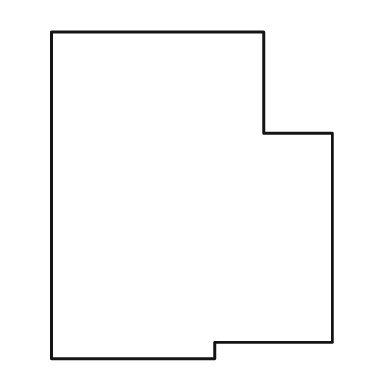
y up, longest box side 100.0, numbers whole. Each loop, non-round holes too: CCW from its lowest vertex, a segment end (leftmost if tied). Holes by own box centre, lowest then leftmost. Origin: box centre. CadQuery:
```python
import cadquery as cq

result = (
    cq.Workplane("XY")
    .moveTo(-43.0, -50.0)
    .lineTo(7.0, -50.0)
    .lineTo(7.0, -45.0)
    .lineTo(43.0, -45.0)
    .lineTo(43.0, 19.0)
    .lineTo(22.0, 19.0)
    .lineTo(22.0, 50.0)
    .lineTo(-43.0, 50.0)
    .close()
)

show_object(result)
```